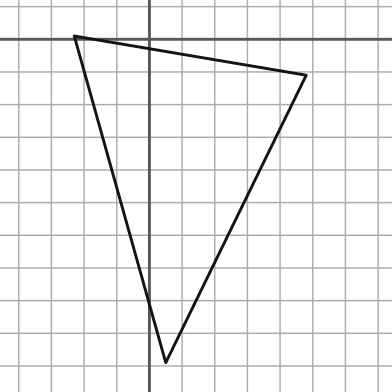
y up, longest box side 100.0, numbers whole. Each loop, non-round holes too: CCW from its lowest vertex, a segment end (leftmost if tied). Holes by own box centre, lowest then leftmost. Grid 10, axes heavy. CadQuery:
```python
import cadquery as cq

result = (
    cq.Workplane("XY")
    .moveTo(5.0, -99.0)
    .lineTo(48.0, -11.0)
    .lineTo(-23.0, 1.0)
    .close()
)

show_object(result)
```